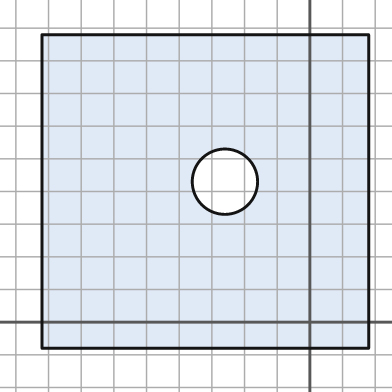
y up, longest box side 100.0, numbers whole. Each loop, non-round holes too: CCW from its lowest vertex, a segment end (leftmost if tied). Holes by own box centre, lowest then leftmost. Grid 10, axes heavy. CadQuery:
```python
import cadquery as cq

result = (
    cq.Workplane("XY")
    .moveTo(-82.0, -8.0)
    .lineTo(18.0, -8.0)
    .lineTo(18.0, 88.0)
    .lineTo(-82.0, 88.0)
    .close()
    .moveTo(-26.0, 43.0)
    .circle(10.0)
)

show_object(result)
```